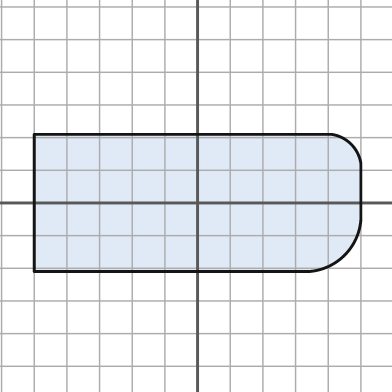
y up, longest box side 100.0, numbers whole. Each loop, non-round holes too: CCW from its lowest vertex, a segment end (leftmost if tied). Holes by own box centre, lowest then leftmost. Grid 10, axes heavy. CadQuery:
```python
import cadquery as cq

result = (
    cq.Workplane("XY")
    .moveTo(-50.0, -21.0)
    .lineTo(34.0, -21.0)
    .threePointArc((45.0, -16.0), (50.0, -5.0))
    .lineTo(50.0, 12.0)
    .threePointArc((47.0, 18.0), (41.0, 21.0))
    .lineTo(-50.0, 21.0)
    .close()
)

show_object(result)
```